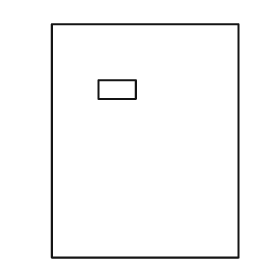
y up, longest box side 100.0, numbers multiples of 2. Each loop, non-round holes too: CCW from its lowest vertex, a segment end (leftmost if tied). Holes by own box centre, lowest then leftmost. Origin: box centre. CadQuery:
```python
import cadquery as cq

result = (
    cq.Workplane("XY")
    .moveTo(-40.0, -50.0)
    .lineTo(40.0, -50.0)
    .lineTo(40.0, 50.0)
    .lineTo(-40.0, 50.0)
    .close()
    .moveTo(-20.0, 18.0)
    .lineTo(-4.0, 18.0)
    .lineTo(-4.0, 26.0)
    .lineTo(-20.0, 26.0)
    .close()
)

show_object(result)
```